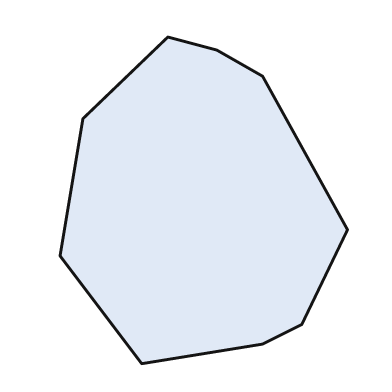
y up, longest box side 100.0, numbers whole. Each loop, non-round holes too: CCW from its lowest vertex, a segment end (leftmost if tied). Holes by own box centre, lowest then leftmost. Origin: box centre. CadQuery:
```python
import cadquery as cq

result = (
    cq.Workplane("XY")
    .moveTo(-19.0, -50.0)
    .lineTo(18.0, -44.0)
    .lineTo(30.0, -38.0)
    .lineTo(44.0, -9.0)
    .lineTo(18.0, 38.0)
    .lineTo(4.0, 46.0)
    .lineTo(-11.0, 50.0)
    .lineTo(-37.0, 25.0)
    .lineTo(-44.0, -17.0)
    .close()
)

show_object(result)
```